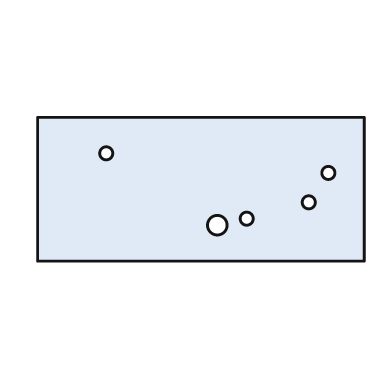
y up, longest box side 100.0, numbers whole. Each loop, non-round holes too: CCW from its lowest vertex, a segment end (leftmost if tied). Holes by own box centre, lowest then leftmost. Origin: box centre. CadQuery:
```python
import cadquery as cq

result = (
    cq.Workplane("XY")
    .moveTo(-50.0, -22.0)
    .lineTo(50.0, -22.0)
    .lineTo(50.0, 22.0)
    .lineTo(-50.0, 22.0)
    .close()
    .moveTo(5.0, -11.0)
    .circle(3.0)
    .moveTo(14.0, -9.0)
    .circle(2.0)
    .moveTo(33.0, -4.0)
    .circle(2.0)
    .moveTo(39.0, 5.0)
    .circle(2.0)
    .moveTo(-29.0, 11.0)
    .circle(2.0)
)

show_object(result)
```